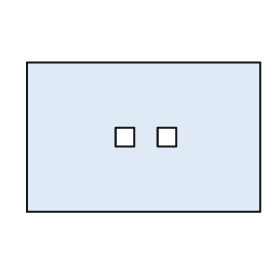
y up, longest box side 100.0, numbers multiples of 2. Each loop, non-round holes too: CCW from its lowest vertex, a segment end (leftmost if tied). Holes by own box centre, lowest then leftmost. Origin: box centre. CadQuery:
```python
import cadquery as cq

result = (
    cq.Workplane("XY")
    .moveTo(-50.0, -32.0)
    .lineTo(50.0, -32.0)
    .lineTo(50.0, 32.0)
    .lineTo(-50.0, 32.0)
    .close()
    .moveTo(-12.0, -4.0)
    .lineTo(-4.0, -4.0)
    .lineTo(-4.0, 4.0)
    .lineTo(-12.0, 4.0)
    .close()
    .moveTo(6.0, -4.0)
    .lineTo(14.0, -4.0)
    .lineTo(14.0, 4.0)
    .lineTo(6.0, 4.0)
    .close()
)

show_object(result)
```